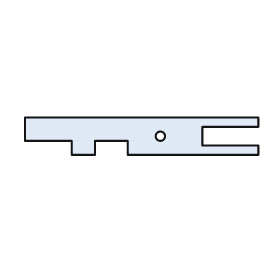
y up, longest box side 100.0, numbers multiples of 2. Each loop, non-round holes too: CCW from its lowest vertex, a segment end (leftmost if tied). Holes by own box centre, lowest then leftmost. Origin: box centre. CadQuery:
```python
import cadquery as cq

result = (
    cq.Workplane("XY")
    .moveTo(-30.0, -8.0)
    .lineTo(-20.0, -8.0)
    .lineTo(-20.0, -2.0)
    .lineTo(-6.0, -2.0)
    .lineTo(-6.0, -8.0)
    .lineTo(50.0, -8.0)
    .lineTo(50.0, -4.0)
    .lineTo(26.0, -4.0)
    .lineTo(26.0, 4.0)
    .lineTo(50.0, 4.0)
    .lineTo(50.0, 8.0)
    .lineTo(-50.0, 8.0)
    .lineTo(-50.0, -2.0)
    .lineTo(-30.0, -2.0)
    .close()
    .moveTo(8.0, 0.0)
    .circle(2.0)
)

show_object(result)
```